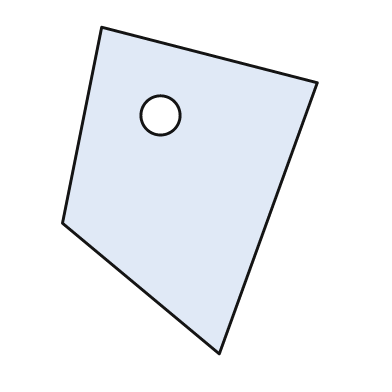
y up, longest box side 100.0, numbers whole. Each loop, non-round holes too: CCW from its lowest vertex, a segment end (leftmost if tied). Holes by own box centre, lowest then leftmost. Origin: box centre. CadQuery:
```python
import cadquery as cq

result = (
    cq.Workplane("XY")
    .moveTo(9.0, -50.0)
    .lineTo(39.0, 33.0)
    .lineTo(-27.0, 50.0)
    .lineTo(-39.0, -10.0)
    .close()
    .moveTo(-9.0, 23.0)
    .circle(6.0)
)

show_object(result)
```